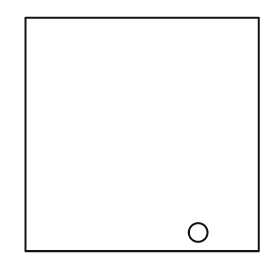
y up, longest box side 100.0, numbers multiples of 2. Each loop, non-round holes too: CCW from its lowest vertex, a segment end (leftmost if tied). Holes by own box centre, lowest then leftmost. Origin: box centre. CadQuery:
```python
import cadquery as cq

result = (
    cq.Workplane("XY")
    .moveTo(-50.0, -50.0)
    .lineTo(50.0, -50.0)
    .lineTo(50.0, 50.0)
    .lineTo(-50.0, 50.0)
    .close()
    .moveTo(24.0, -42.0)
    .circle(4.0)
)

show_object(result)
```